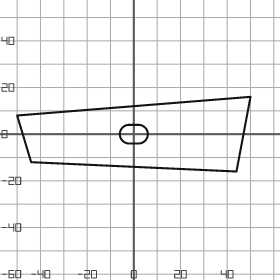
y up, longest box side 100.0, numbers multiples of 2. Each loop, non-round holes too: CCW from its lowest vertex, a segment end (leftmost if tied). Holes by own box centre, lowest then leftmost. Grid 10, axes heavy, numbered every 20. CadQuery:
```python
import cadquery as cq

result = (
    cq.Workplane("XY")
    .moveTo(44.0, -16.0)
    .lineTo(50.0, 16.0)
    .lineTo(-50.0, 8.0)
    .lineTo(-44.0, -12.0)
    .close()
    .moveTo(-2.0, -4.0)
    .lineTo(2.0, -4.0)
    .threePointArc((6.0, 0.0), (2.0, 4.0))
    .lineTo(-2.0, 4.0)
    .threePointArc((-6.0, 0.0), (-2.0, -4.0))
    .close()
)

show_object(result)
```